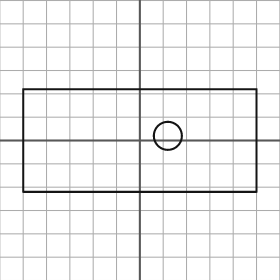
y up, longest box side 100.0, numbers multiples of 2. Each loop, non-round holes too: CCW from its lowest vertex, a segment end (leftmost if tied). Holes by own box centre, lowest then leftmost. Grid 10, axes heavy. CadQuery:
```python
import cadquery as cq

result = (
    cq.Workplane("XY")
    .moveTo(-50.0, -22.0)
    .lineTo(50.0, -22.0)
    .lineTo(50.0, 22.0)
    .lineTo(-50.0, 22.0)
    .close()
    .moveTo(12.0, 2.0)
    .circle(6.0)
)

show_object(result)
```